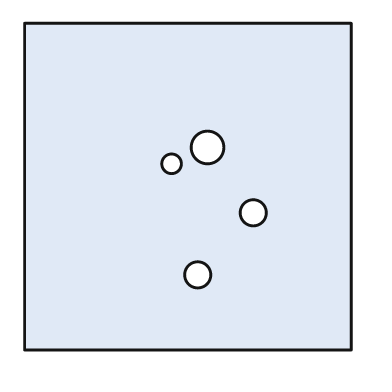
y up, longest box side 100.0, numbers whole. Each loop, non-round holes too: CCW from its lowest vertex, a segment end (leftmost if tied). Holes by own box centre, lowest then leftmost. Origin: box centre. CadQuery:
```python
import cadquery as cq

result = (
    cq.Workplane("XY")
    .moveTo(-50.0, -50.0)
    .lineTo(50.0, -50.0)
    .lineTo(50.0, 50.0)
    .lineTo(-50.0, 50.0)
    .close()
    .moveTo(3.0, -27.0)
    .circle(4.0)
    .moveTo(20.0, -8.0)
    .circle(4.0)
    .moveTo(-5.0, 7.0)
    .circle(3.0)
    .moveTo(6.0, 12.0)
    .circle(5.0)
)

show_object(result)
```